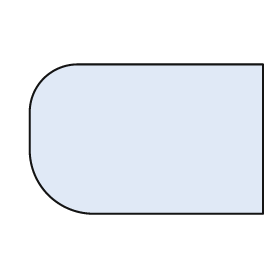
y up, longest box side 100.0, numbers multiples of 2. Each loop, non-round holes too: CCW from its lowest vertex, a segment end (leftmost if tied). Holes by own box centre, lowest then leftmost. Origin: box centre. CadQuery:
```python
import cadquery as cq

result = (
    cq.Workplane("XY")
    .moveTo(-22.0, -32.0)
    .lineTo(50.0, -32.0)
    .lineTo(50.0, 32.0)
    .lineTo(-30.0, 32.0)
    .threePointArc((-44.0, 26.0), (-50.0, 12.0))
    .lineTo(-50.0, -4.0)
    .threePointArc((-42.0, -24.0), (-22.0, -32.0))
    .close()
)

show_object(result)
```